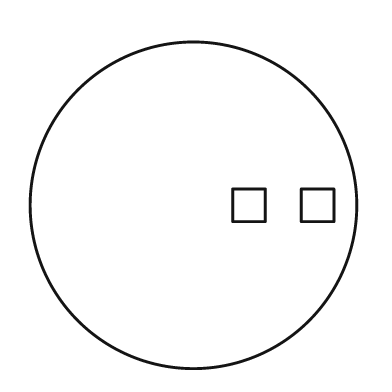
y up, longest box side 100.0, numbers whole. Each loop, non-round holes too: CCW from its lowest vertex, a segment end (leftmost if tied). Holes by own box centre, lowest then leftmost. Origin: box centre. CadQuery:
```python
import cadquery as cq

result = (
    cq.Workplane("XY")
    .moveTo(0.0, 0.0)
    .circle(50.0)
    .moveTo(12.0, -5.0)
    .lineTo(22.0, -5.0)
    .lineTo(22.0, 5.0)
    .lineTo(12.0, 5.0)
    .close()
    .moveTo(33.0, -5.0)
    .lineTo(43.0, -5.0)
    .lineTo(43.0, 5.0)
    .lineTo(33.0, 5.0)
    .close()
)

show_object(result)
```